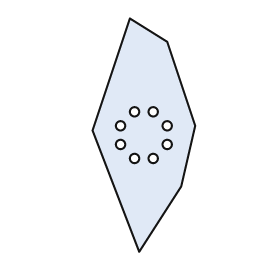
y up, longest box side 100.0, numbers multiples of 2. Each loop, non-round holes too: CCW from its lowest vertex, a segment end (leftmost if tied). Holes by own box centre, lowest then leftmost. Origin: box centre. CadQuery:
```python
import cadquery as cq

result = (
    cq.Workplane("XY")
    .moveTo(-2.0, -50.0)
    .lineTo(16.0, -22.0)
    .lineTo(22.0, 4.0)
    .lineTo(10.0, 40.0)
    .lineTo(-6.0, 50.0)
    .lineTo(-22.0, 2.0)
    .close()
    .moveTo(-4.0, -10.0)
    .circle(2.0)
    .moveTo(4.0, -10.0)
    .circle(2.0)
    .moveTo(-10.0, -4.0)
    .circle(2.0)
    .moveTo(10.0, -4.0)
    .circle(2.0)
    .moveTo(-10.0, 4.0)
    .circle(2.0)
    .moveTo(10.0, 4.0)
    .circle(2.0)
    .moveTo(-4.0, 10.0)
    .circle(2.0)
    .moveTo(4.0, 10.0)
    .circle(2.0)
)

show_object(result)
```